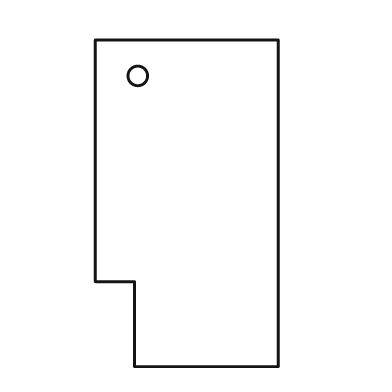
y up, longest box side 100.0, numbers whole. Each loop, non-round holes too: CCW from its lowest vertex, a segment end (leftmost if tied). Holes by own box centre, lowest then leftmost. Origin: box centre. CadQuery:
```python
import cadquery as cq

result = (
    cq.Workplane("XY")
    .moveTo(-16.0, -50.0)
    .lineTo(28.0, -50.0)
    .lineTo(28.0, 50.0)
    .lineTo(-28.0, 50.0)
    .lineTo(-28.0, -24.0)
    .lineTo(-16.0, -24.0)
    .close()
    .moveTo(-15.0, 39.0)
    .circle(3.0)
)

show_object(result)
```